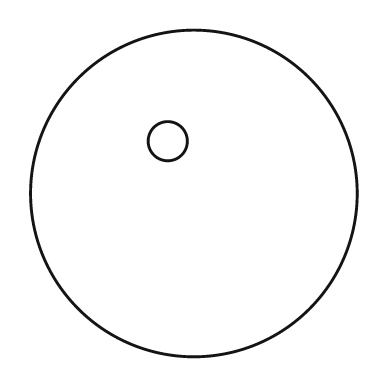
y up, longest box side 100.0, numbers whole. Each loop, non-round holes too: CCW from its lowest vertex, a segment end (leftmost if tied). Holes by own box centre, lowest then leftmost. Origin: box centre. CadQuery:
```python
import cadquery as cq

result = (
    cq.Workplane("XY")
    .moveTo(0.0, 0.0)
    .circle(50.0)
    .moveTo(-8.0, 16.0)
    .circle(6.0)
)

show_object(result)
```